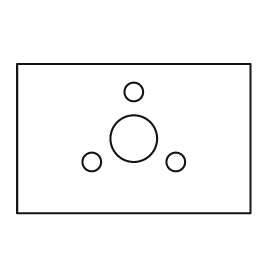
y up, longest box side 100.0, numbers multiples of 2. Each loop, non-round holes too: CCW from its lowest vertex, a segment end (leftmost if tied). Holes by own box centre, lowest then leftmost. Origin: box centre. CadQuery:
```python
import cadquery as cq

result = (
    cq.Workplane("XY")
    .moveTo(-50.0, -32.0)
    .lineTo(50.0, -32.0)
    .lineTo(50.0, 32.0)
    .lineTo(-50.0, 32.0)
    .close()
    .moveTo(-18.0, -10.0)
    .circle(4.0)
    .moveTo(18.0, -10.0)
    .circle(4.0)
    .moveTo(0.0, 0.0)
    .circle(10.0)
    .moveTo(0.0, 20.0)
    .circle(4.0)
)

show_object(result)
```